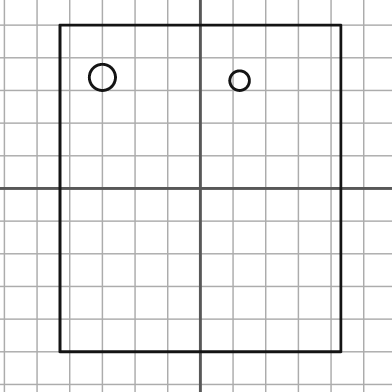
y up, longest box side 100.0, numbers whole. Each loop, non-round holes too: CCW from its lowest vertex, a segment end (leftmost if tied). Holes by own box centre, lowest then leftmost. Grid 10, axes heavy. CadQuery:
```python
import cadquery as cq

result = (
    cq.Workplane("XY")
    .moveTo(-43.0, -50.0)
    .lineTo(43.0, -50.0)
    .lineTo(43.0, 50.0)
    .lineTo(-43.0, 50.0)
    .close()
    .moveTo(12.0, 33.0)
    .circle(3.0)
    .moveTo(-30.0, 34.0)
    .circle(4.0)
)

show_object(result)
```